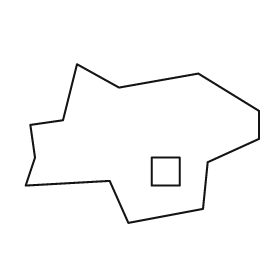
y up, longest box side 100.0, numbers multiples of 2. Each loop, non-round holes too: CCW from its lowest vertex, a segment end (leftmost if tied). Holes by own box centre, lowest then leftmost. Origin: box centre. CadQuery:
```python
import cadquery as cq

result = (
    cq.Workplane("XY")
    .moveTo(-6.0, -34.0)
    .lineTo(26.0, -28.0)
    .lineTo(28.0, -8.0)
    .lineTo(50.0, 2.0)
    .lineTo(50.0, 14.0)
    .lineTo(24.0, 30.0)
    .lineTo(-10.0, 24.0)
    .lineTo(-28.0, 34.0)
    .lineTo(-34.0, 10.0)
    .lineTo(-48.0, 8.0)
    .lineTo(-46.0, -6.0)
    .lineTo(-50.0, -18.0)
    .lineTo(-14.0, -16.0)
    .close()
    .moveTo(4.0, -18.0)
    .lineTo(16.0, -18.0)
    .lineTo(16.0, -6.0)
    .lineTo(4.0, -6.0)
    .close()
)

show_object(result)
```